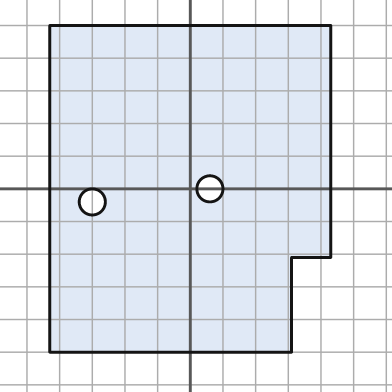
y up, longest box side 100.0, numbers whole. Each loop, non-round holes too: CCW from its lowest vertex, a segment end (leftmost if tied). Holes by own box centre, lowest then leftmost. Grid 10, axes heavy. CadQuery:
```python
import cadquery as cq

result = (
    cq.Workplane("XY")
    .moveTo(-43.0, -50.0)
    .lineTo(31.0, -50.0)
    .lineTo(31.0, -21.0)
    .lineTo(43.0, -21.0)
    .lineTo(43.0, 50.0)
    .lineTo(-43.0, 50.0)
    .close()
    .moveTo(-30.0, -4.0)
    .circle(4.0)
    .moveTo(6.0, 0.0)
    .circle(4.0)
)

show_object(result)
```